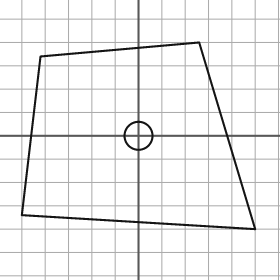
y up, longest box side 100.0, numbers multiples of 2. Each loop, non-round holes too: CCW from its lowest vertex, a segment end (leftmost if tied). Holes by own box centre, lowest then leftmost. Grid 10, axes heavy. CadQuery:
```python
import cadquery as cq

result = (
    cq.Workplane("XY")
    .moveTo(50.0, -40.0)
    .lineTo(26.0, 40.0)
    .lineTo(-42.0, 34.0)
    .lineTo(-50.0, -34.0)
    .close()
    .moveTo(0.0, 0.0)
    .circle(6.0)
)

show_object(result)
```